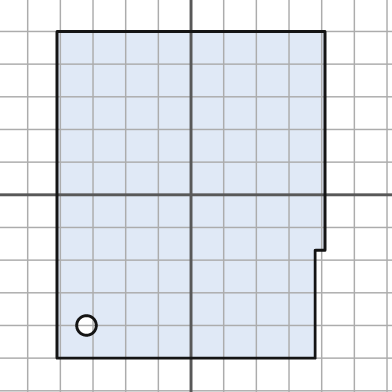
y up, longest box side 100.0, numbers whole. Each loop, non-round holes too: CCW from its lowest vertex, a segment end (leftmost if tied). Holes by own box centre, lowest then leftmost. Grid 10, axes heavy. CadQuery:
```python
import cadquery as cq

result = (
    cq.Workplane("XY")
    .moveTo(-41.0, -50.0)
    .lineTo(38.0, -50.0)
    .lineTo(38.0, -17.0)
    .lineTo(41.0, -17.0)
    .lineTo(41.0, 50.0)
    .lineTo(-41.0, 50.0)
    .close()
    .moveTo(-32.0, -40.0)
    .circle(3.0)
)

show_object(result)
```